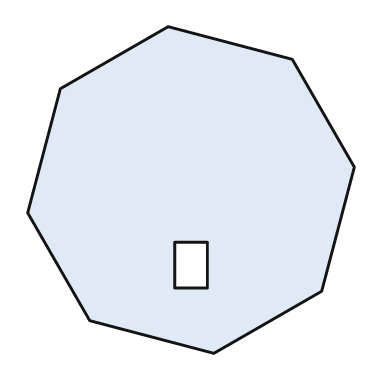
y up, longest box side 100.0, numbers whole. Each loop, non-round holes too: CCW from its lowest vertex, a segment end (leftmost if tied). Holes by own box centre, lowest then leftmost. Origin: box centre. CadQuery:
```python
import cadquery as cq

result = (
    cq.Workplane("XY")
    .moveTo(7.0, -50.0)
    .lineTo(40.0, -31.0)
    .lineTo(50.0, 7.0)
    .lineTo(31.0, 40.0)
    .lineTo(-7.0, 50.0)
    .lineTo(-40.0, 31.0)
    .lineTo(-50.0, -7.0)
    .lineTo(-31.0, -40.0)
    .close()
    .moveTo(-5.0, -30.0)
    .lineTo(5.0, -30.0)
    .lineTo(5.0, -16.0)
    .lineTo(-5.0, -16.0)
    .close()
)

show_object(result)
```